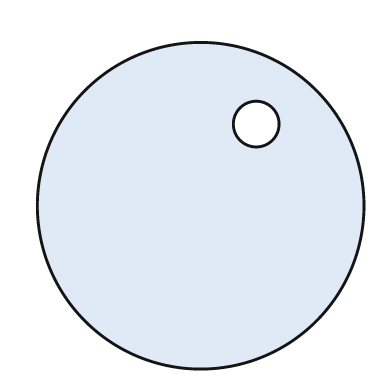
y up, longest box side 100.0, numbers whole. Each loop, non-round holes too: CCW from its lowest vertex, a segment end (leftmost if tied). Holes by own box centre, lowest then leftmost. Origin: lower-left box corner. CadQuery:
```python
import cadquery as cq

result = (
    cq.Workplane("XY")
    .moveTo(50.0, 50.0)
    .circle(50.0)
    .moveTo(67.0, 75.0)
    .circle(7.0)
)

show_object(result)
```